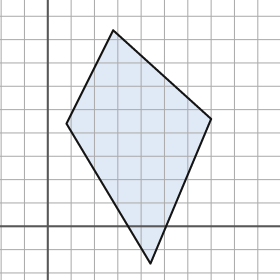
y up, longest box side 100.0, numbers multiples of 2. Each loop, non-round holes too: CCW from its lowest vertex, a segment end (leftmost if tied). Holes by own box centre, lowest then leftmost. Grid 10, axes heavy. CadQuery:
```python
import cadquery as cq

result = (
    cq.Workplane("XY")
    .moveTo(44.0, -16.0)
    .lineTo(70.0, 46.0)
    .lineTo(28.0, 84.0)
    .lineTo(8.0, 44.0)
    .close()
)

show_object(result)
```